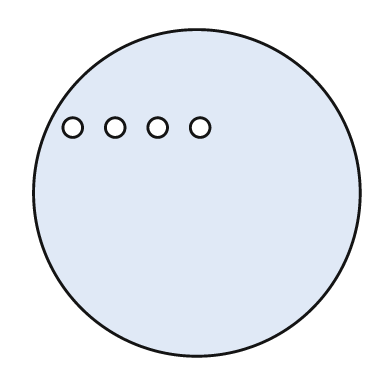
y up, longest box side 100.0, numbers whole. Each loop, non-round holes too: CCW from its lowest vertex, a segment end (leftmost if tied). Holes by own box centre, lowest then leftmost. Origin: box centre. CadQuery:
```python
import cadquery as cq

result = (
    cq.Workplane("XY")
    .moveTo(0.0, 0.0)
    .circle(50.0)
    .moveTo(-38.0, 20.0)
    .circle(3.0)
    .moveTo(-25.0, 20.0)
    .circle(3.0)
    .moveTo(-12.0, 20.0)
    .circle(3.0)
    .moveTo(1.0, 20.0)
    .circle(3.0)
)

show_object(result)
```